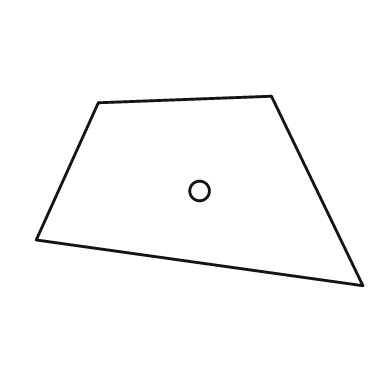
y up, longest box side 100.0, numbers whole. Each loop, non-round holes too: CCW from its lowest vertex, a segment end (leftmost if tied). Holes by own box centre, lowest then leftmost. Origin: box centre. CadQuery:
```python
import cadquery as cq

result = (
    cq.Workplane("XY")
    .moveTo(50.0, -29.0)
    .lineTo(22.0, 29.0)
    .lineTo(-31.0, 27.0)
    .lineTo(-50.0, -15.0)
    .close()
    .moveTo(0.0, 0.0)
    .circle(3.0)
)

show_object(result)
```